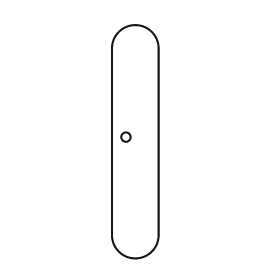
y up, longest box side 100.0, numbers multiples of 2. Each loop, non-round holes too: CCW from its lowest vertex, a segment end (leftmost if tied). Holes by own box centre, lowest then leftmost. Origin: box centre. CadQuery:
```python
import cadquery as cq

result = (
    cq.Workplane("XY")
    .moveTo(-10.0, -40.0)
    .threePointArc((0.0, -50.0), (10.0, -40.0))
    .lineTo(10.0, 40.0)
    .threePointArc((0.0, 50.0), (-10.0, 40.0))
    .close()
    .moveTo(-4.0, 2.0)
    .circle(2.0)
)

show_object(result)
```